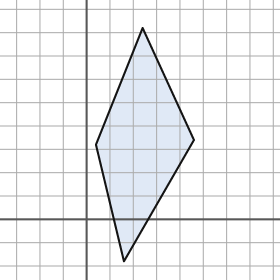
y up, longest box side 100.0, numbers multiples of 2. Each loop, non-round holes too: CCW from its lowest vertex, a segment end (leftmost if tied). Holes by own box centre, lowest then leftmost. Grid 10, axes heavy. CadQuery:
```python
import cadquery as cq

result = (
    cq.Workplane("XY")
    .moveTo(16.0, -18.0)
    .lineTo(46.0, 34.0)
    .lineTo(24.0, 82.0)
    .lineTo(4.0, 32.0)
    .close()
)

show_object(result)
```